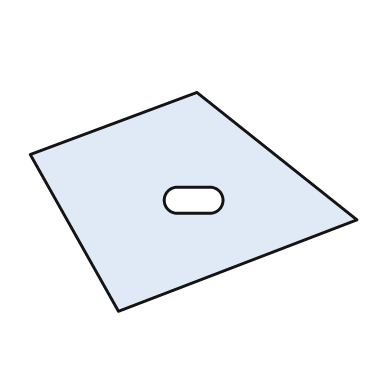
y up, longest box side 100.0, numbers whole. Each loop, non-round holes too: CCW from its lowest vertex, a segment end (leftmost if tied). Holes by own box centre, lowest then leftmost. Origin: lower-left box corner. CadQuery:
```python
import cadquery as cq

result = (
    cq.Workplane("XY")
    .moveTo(27.0, 0.0)
    .lineTo(100.0, 28.0)
    .lineTo(51.0, 67.0)
    .lineTo(0.0, 48.0)
    .close()
    .moveTo(45.0, 30.0)
    .lineTo(55.0, 30.0)
    .threePointArc((59.0, 34.0), (55.0, 38.0))
    .lineTo(45.0, 38.0)
    .threePointArc((41.0, 34.0), (45.0, 30.0))
    .close()
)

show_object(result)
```